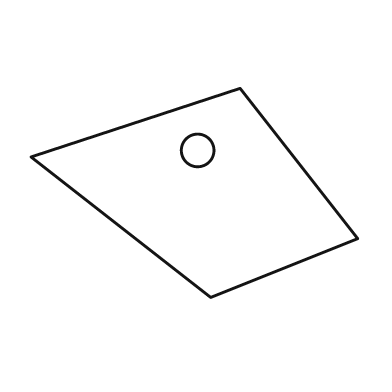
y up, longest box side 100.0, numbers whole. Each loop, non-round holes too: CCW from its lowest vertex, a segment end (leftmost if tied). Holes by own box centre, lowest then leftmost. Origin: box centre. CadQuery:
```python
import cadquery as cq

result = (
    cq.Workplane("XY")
    .moveTo(5.0, -32.0)
    .lineTo(50.0, -14.0)
    .lineTo(14.0, 32.0)
    .lineTo(-50.0, 11.0)
    .close()
    .moveTo(1.0, 13.0)
    .circle(5.0)
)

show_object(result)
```